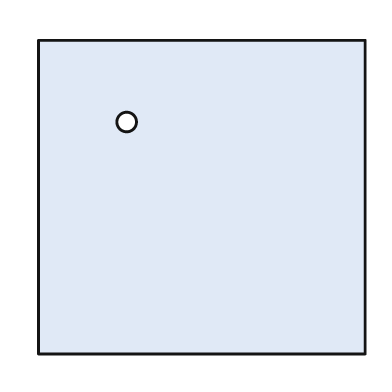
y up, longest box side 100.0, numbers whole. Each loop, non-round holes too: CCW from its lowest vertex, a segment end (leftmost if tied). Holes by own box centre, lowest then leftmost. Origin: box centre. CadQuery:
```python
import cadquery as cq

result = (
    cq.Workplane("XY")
    .moveTo(-50.0, -48.0)
    .lineTo(50.0, -48.0)
    .lineTo(50.0, 48.0)
    .lineTo(-50.0, 48.0)
    .close()
    .moveTo(-23.0, 23.0)
    .circle(3.0)
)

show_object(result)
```